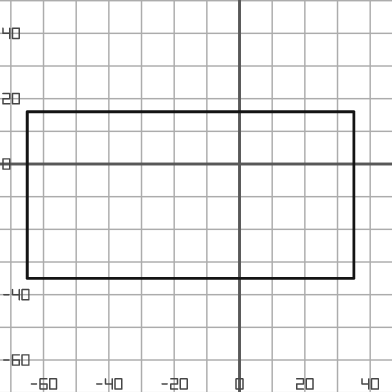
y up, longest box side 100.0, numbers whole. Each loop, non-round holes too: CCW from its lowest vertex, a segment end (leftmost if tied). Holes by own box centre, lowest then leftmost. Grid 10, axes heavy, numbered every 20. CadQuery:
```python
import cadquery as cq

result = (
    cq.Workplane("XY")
    .moveTo(-65.0, -35.0)
    .lineTo(35.0, -35.0)
    .lineTo(35.0, 16.0)
    .lineTo(-65.0, 16.0)
    .close()
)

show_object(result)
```